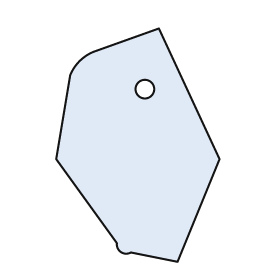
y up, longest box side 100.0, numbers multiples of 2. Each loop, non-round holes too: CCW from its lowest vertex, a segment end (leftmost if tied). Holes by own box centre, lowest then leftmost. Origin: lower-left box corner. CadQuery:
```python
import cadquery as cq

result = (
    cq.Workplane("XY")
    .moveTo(52.0, 0.0)
    .lineTo(70.0, 44.0)
    .lineTo(44.0, 100.0)
    .lineTo(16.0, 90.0)
    .threePointArc((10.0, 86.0), (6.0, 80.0))
    .lineTo(0.0, 44.0)
    .lineTo(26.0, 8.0)
    .threePointArc((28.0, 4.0), (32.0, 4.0))
    .close()
    .moveTo(38.0, 74.0)
    .circle(4.0)
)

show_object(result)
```